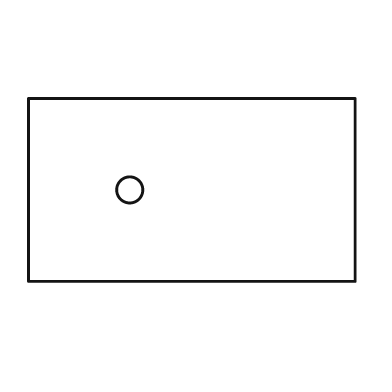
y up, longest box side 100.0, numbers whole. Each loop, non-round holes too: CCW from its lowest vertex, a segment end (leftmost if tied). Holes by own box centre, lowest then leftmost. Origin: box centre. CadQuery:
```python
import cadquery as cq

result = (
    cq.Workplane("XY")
    .moveTo(-50.0, -28.0)
    .lineTo(50.0, -28.0)
    .lineTo(50.0, 28.0)
    .lineTo(-50.0, 28.0)
    .close()
    .moveTo(-19.0, 0.0)
    .circle(4.0)
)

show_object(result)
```